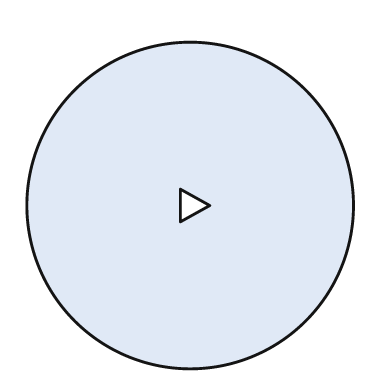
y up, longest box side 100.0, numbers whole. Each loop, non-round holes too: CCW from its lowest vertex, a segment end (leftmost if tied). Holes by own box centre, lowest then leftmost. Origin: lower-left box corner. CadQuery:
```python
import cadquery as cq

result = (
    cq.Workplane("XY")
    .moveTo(50.0, 50.0)
    .circle(50.0)
    .moveTo(47.0, 45.0)
    .lineTo(56.0, 50.0)
    .lineTo(47.0, 55.0)
    .close()
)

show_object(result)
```